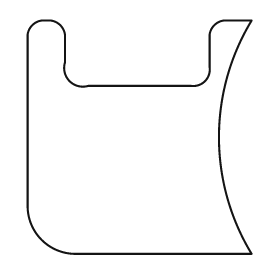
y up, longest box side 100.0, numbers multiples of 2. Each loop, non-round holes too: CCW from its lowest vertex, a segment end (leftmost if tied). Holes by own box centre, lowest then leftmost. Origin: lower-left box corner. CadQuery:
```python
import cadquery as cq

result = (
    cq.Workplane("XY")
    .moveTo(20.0, 0.0)
    .lineTo(96.0, 0.0)
    .threePointArc((82.0, 50.0), (96.0, 100.0))
    .lineTo(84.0, 100.0)
    .threePointArc((80.0, 98.0), (78.0, 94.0))
    .lineTo(78.0, 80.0)
    .threePointArc((76.0, 74.0), (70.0, 72.0))
    .lineTo(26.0, 72.0)
    .threePointArc((18.0, 74.0), (16.0, 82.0))
    .lineTo(16.0, 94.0)
    .threePointArc((14.0, 98.0), (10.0, 100.0))
    .lineTo(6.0, 100.0)
    .threePointArc((2.0, 98.0), (0.0, 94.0))
    .lineTo(0.0, 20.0)
    .threePointArc((6.0, 6.0), (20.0, 0.0))
    .close()
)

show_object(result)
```